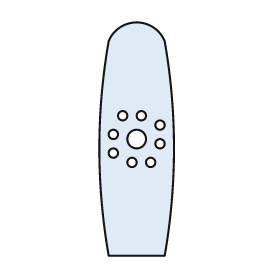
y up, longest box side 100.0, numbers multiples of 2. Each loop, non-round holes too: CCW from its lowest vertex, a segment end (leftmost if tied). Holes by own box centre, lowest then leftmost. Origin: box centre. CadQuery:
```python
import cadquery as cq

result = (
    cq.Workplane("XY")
    .moveTo(-12.0, -50.0)
    .lineTo(12.0, -50.0)
    .threePointArc((16.0, -4.0), (12.0, 42.0))
    .threePointArc((0.0, 50.0), (-12.0, 42.0))
    .threePointArc((-16.0, -4.0), (-12.0, -50.0))
    .close()
    .moveTo(-2.0, -10.0)
    .circle(2.0)
    .moveTo(6.0, -10.0)
    .circle(2.0)
    .moveTo(-10.0, -6.0)
    .circle(2.0)
    .moveTo(10.0, -2.0)
    .circle(2.0)
    .moveTo(0.0, 0.0)
    .circle(4.0)
    .moveTo(-10.0, 2.0)
    .circle(2.0)
    .moveTo(10.0, 6.0)
    .circle(2.0)
    .moveTo(-6.0, 10.0)
    .circle(2.0)
    .moveTo(2.0, 10.0)
    .circle(2.0)
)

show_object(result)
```